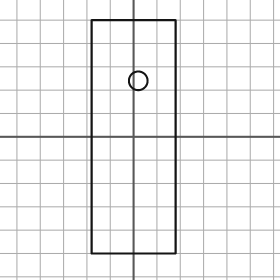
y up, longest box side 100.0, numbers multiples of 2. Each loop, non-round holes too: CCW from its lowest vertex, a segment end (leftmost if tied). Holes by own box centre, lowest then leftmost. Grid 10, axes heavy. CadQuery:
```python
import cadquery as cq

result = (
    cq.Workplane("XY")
    .moveTo(-18.0, -50.0)
    .lineTo(18.0, -50.0)
    .lineTo(18.0, 50.0)
    .lineTo(-18.0, 50.0)
    .close()
    .moveTo(2.0, 24.0)
    .circle(4.0)
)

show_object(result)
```